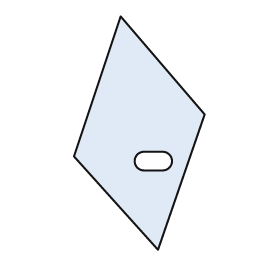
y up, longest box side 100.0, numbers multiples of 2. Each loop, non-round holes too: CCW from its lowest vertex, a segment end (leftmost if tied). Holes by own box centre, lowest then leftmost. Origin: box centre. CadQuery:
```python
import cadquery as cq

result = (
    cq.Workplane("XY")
    .moveTo(8.0, -50.0)
    .lineTo(28.0, 8.0)
    .lineTo(-8.0, 50.0)
    .lineTo(-28.0, -10.0)
    .close()
    .moveTo(2.0, -16.0)
    .lineTo(10.0, -16.0)
    .threePointArc((14.0, -12.0), (10.0, -8.0))
    .lineTo(2.0, -8.0)
    .threePointArc((-2.0, -12.0), (2.0, -16.0))
    .close()
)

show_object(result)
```